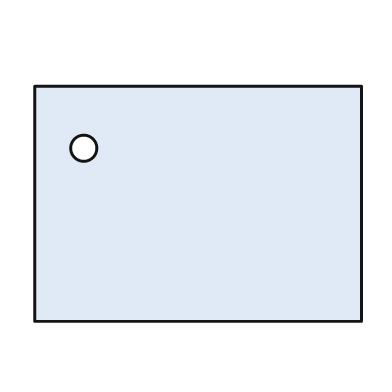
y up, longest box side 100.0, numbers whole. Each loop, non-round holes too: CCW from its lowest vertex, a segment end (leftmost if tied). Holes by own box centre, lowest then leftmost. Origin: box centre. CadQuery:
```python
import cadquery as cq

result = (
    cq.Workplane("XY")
    .moveTo(-50.0, -36.0)
    .lineTo(50.0, -36.0)
    .lineTo(50.0, 36.0)
    .lineTo(-50.0, 36.0)
    .close()
    .moveTo(-35.0, 17.0)
    .circle(4.0)
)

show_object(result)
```